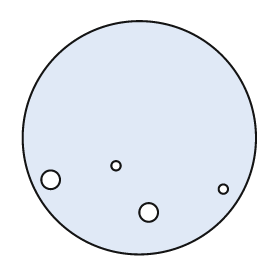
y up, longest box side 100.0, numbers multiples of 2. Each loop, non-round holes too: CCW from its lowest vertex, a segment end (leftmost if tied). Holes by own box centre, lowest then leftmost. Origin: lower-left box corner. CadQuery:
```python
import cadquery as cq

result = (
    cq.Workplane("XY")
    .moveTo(50.0, 50.0)
    .circle(50.0)
    .moveTo(54.0, 18.0)
    .circle(4.0)
    .moveTo(86.0, 28.0)
    .circle(2.0)
    .moveTo(12.0, 32.0)
    .circle(4.0)
    .moveTo(40.0, 38.0)
    .circle(2.0)
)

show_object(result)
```